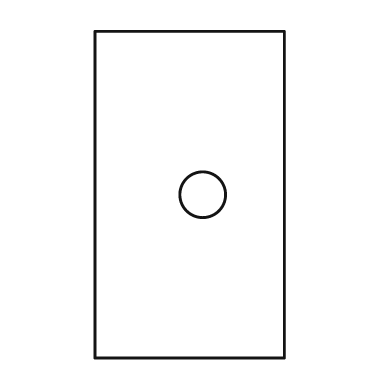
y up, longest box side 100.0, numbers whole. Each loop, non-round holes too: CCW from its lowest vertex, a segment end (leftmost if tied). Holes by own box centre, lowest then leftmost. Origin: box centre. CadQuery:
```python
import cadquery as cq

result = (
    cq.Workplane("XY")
    .moveTo(-29.0, -50.0)
    .lineTo(29.0, -50.0)
    .lineTo(29.0, 50.0)
    .lineTo(-29.0, 50.0)
    .close()
    .moveTo(4.0, 0.0)
    .circle(7.0)
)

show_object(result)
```